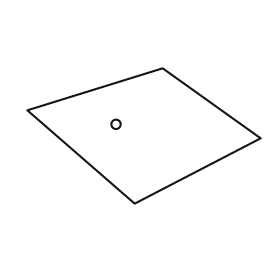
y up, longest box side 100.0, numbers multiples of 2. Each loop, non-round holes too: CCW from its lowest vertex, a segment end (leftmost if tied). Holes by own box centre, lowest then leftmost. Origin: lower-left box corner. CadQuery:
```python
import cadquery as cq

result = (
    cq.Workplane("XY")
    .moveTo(46.0, 0.0)
    .lineTo(100.0, 28.0)
    .lineTo(58.0, 58.0)
    .lineTo(0.0, 40.0)
    .close()
    .moveTo(38.0, 34.0)
    .circle(2.0)
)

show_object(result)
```